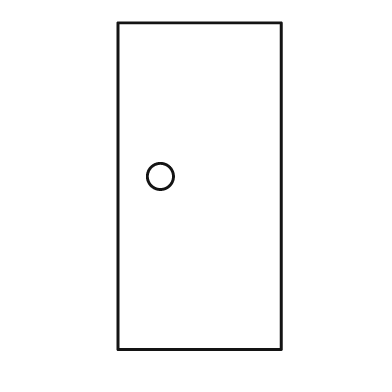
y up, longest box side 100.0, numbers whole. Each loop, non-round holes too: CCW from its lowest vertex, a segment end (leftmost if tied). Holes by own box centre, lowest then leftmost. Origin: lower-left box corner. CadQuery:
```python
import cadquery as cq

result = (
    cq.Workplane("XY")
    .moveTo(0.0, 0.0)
    .lineTo(50.0, 0.0)
    .lineTo(50.0, 100.0)
    .lineTo(0.0, 100.0)
    .close()
    .moveTo(13.0, 53.0)
    .circle(4.0)
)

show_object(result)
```